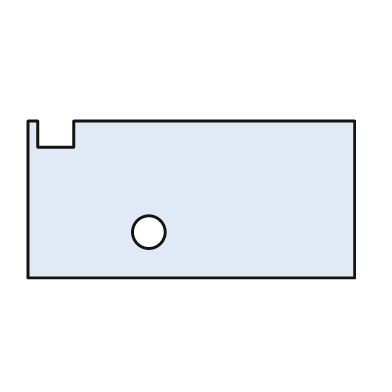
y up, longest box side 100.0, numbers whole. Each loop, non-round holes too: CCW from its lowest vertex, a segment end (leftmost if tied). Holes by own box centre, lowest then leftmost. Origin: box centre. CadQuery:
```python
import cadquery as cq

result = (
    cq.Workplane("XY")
    .moveTo(-50.0, -24.0)
    .lineTo(50.0, -24.0)
    .lineTo(50.0, 24.0)
    .lineTo(-36.0, 24.0)
    .lineTo(-36.0, 16.0)
    .lineTo(-47.0, 16.0)
    .lineTo(-47.0, 24.0)
    .lineTo(-50.0, 24.0)
    .close()
    .moveTo(-13.0, -10.0)
    .circle(5.0)
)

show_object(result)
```